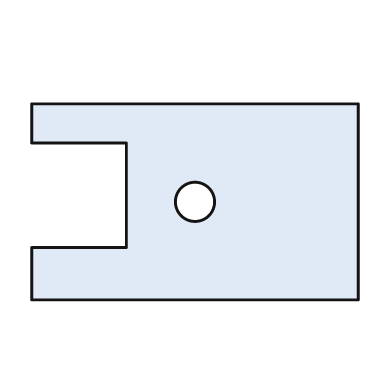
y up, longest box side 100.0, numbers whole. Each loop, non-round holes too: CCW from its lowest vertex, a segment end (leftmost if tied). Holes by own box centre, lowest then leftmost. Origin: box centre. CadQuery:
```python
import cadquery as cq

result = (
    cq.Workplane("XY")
    .moveTo(-50.0, -30.0)
    .lineTo(50.0, -30.0)
    .lineTo(50.0, 30.0)
    .lineTo(-50.0, 30.0)
    .lineTo(-50.0, 18.0)
    .lineTo(-21.0, 18.0)
    .lineTo(-21.0, -14.0)
    .lineTo(-50.0, -14.0)
    .close()
    .moveTo(0.0, 0.0)
    .circle(6.0)
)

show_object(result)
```